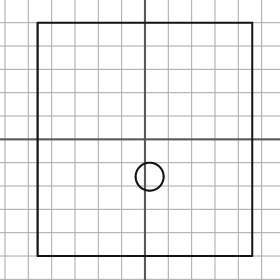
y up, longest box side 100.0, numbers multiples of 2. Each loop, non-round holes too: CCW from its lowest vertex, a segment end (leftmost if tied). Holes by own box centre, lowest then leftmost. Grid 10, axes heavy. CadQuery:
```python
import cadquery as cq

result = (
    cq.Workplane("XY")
    .moveTo(-46.0, -50.0)
    .lineTo(46.0, -50.0)
    .lineTo(46.0, 50.0)
    .lineTo(-46.0, 50.0)
    .close()
    .moveTo(2.0, -16.0)
    .circle(6.0)
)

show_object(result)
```